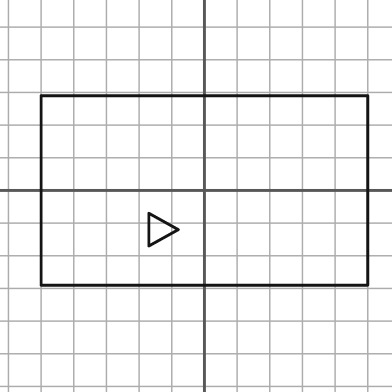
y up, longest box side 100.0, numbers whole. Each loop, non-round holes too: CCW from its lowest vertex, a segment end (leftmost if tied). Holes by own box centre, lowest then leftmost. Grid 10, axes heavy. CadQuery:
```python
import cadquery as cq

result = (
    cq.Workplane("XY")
    .moveTo(-50.0, -29.0)
    .lineTo(50.0, -29.0)
    .lineTo(50.0, 29.0)
    .lineTo(-50.0, 29.0)
    .close()
    .moveTo(-17.0, -17.0)
    .lineTo(-8.0, -12.0)
    .lineTo(-17.0, -7.0)
    .close()
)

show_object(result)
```